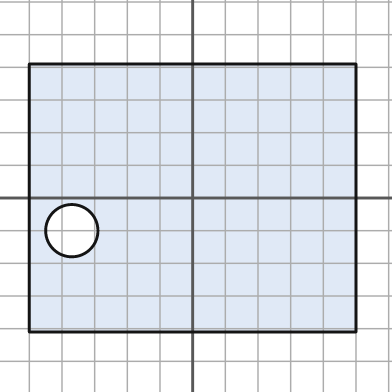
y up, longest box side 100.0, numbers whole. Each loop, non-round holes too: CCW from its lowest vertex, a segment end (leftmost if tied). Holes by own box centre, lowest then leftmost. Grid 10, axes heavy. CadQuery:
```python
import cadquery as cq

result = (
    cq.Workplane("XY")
    .moveTo(-50.0, -41.0)
    .lineTo(50.0, -41.0)
    .lineTo(50.0, 41.0)
    .lineTo(-50.0, 41.0)
    .close()
    .moveTo(-37.0, -10.0)
    .circle(8.0)
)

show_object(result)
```